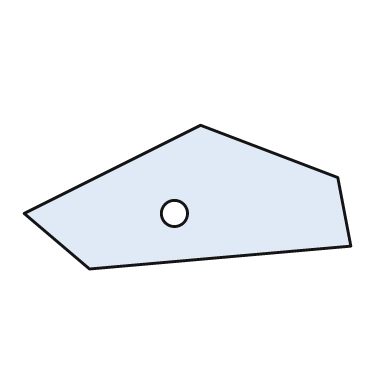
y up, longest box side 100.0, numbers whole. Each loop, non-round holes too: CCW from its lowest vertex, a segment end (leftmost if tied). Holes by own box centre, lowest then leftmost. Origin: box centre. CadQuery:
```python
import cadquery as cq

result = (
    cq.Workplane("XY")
    .moveTo(-30.0, -22.0)
    .lineTo(50.0, -15.0)
    .lineTo(46.0, 6.0)
    .lineTo(4.0, 22.0)
    .lineTo(-50.0, -5.0)
    .close()
    .moveTo(-4.0, -5.0)
    .circle(4.0)
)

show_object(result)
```